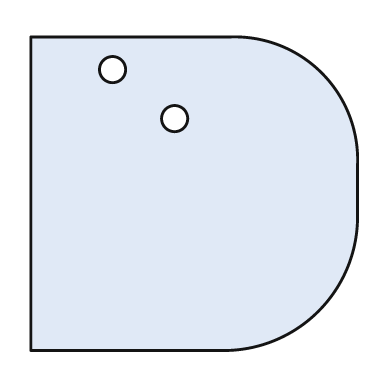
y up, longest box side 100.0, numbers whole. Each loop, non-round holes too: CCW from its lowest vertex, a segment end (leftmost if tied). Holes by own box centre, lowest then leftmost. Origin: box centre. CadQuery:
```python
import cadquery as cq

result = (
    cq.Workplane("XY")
    .moveTo(-50.0, -48.0)
    .lineTo(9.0, -48.0)
    .threePointArc((38.0, -36.0), (50.0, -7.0))
    .lineTo(50.0, 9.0)
    .threePointArc((39.0, 37.0), (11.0, 48.0))
    .lineTo(-50.0, 48.0)
    .close()
    .moveTo(-6.0, 23.0)
    .circle(4.0)
    .moveTo(-25.0, 38.0)
    .circle(4.0)
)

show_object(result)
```